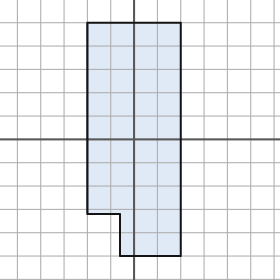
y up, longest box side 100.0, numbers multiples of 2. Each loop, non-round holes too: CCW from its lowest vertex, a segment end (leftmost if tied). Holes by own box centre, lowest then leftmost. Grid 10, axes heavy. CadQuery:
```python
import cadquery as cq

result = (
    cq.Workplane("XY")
    .moveTo(-6.0, -50.0)
    .lineTo(20.0, -50.0)
    .lineTo(20.0, 50.0)
    .lineTo(-20.0, 50.0)
    .lineTo(-20.0, -32.0)
    .lineTo(-6.0, -32.0)
    .close()
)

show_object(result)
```